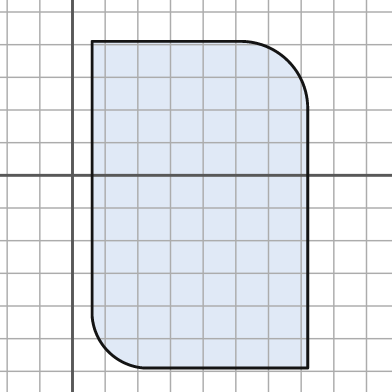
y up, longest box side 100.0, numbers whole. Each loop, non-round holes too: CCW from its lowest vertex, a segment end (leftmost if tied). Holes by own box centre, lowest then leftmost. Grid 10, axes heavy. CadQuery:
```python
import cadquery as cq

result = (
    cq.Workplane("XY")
    .moveTo(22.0, -59.0)
    .lineTo(72.0, -59.0)
    .lineTo(72.0, 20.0)
    .threePointArc((66.0, 35.0), (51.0, 41.0))
    .lineTo(6.0, 41.0)
    .lineTo(6.0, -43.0)
    .threePointArc((11.0, -54.0), (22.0, -59.0))
    .close()
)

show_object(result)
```